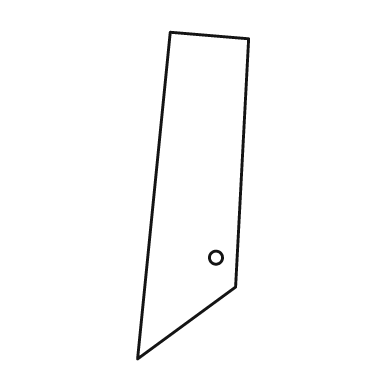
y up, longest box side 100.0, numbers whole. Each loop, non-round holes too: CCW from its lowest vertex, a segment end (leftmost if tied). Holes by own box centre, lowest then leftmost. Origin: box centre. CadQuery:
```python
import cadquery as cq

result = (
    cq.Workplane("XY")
    .moveTo(-17.0, -50.0)
    .lineTo(13.0, -28.0)
    .lineTo(17.0, 48.0)
    .lineTo(-7.0, 50.0)
    .close()
    .moveTo(7.0, -19.0)
    .circle(2.0)
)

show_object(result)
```